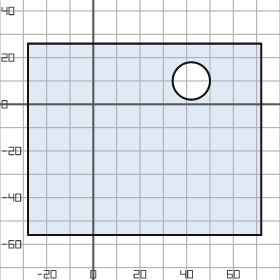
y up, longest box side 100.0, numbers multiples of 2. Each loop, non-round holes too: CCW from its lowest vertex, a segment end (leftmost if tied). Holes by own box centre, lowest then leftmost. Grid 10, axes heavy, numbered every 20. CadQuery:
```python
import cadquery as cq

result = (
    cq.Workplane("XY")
    .moveTo(-28.0, -56.0)
    .lineTo(72.0, -56.0)
    .lineTo(72.0, 26.0)
    .lineTo(-28.0, 26.0)
    .close()
    .moveTo(42.0, 10.0)
    .circle(8.0)
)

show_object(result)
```